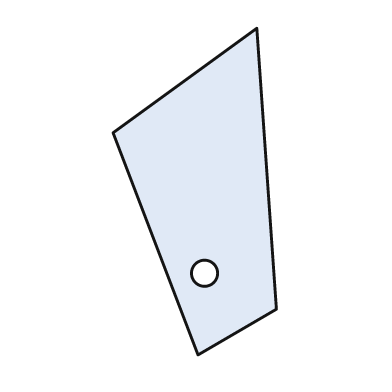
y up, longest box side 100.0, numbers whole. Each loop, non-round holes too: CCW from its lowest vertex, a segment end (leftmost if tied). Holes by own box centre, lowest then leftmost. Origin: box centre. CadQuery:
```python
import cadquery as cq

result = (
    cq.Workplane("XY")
    .moveTo(1.0, -50.0)
    .lineTo(25.0, -36.0)
    .lineTo(19.0, 50.0)
    .lineTo(-25.0, 18.0)
    .close()
    .moveTo(3.0, -25.0)
    .circle(4.0)
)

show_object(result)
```